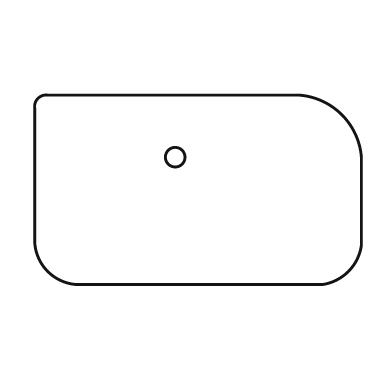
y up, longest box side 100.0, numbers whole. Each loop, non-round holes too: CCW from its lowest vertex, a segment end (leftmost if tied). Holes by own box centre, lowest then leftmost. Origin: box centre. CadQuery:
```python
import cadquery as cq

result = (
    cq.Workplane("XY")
    .moveTo(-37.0, -29.0)
    .lineTo(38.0, -29.0)
    .threePointArc((46.0, -25.0), (50.0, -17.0))
    .lineTo(50.0, 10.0)
    .threePointArc((44.0, 23.0), (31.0, 29.0))
    .lineTo(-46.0, 29.0)
    .threePointArc((-49.0, 28.0), (-50.0, 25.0))
    .lineTo(-50.0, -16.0)
    .threePointArc((-46.0, -25.0), (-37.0, -29.0))
    .close()
    .moveTo(-7.0, 10.0)
    .circle(3.0)
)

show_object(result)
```